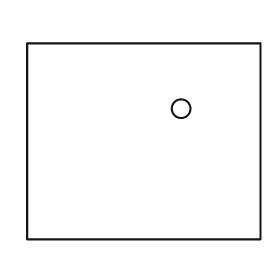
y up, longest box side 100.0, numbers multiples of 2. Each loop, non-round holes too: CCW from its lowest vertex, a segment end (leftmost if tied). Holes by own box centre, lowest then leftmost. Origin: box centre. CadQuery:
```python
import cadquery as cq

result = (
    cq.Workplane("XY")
    .moveTo(-50.0, -42.0)
    .lineTo(50.0, -42.0)
    .lineTo(50.0, 42.0)
    .lineTo(-50.0, 42.0)
    .close()
    .moveTo(16.0, 14.0)
    .circle(4.0)
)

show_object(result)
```